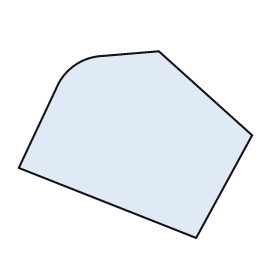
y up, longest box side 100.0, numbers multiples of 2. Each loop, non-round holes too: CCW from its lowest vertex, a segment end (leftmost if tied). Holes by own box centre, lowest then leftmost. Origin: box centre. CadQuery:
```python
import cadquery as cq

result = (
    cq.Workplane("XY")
    .moveTo(26.0, -40.0)
    .lineTo(50.0, 4.0)
    .lineTo(10.0, 40.0)
    .lineTo(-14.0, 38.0)
    .threePointArc((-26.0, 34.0), (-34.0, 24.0))
    .lineTo(-50.0, -10.0)
    .close()
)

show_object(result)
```